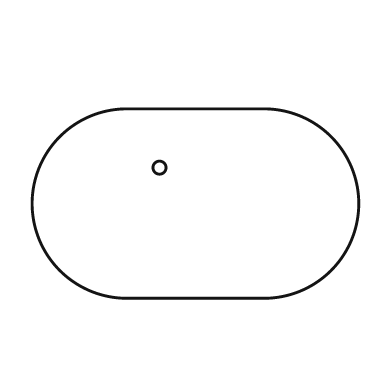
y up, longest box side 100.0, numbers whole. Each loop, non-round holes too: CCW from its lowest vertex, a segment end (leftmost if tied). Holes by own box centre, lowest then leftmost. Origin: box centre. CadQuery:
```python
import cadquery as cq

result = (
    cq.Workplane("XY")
    .moveTo(-21.0, -29.0)
    .lineTo(21.0, -29.0)
    .threePointArc((50.0, 0.0), (21.0, 29.0))
    .lineTo(-21.0, 29.0)
    .threePointArc((-50.0, 0.0), (-21.0, -29.0))
    .close()
    .moveTo(-11.0, 11.0)
    .circle(2.0)
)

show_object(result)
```